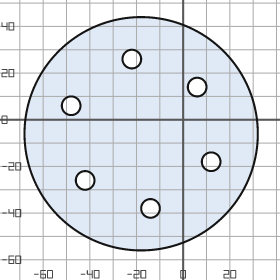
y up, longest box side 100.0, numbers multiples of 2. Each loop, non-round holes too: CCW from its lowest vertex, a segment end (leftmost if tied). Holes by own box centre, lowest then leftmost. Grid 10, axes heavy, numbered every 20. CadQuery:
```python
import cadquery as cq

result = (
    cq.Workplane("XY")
    .moveTo(-18.0, -6.0)
    .circle(50.0)
    .moveTo(-14.0, -38.0)
    .circle(4.0)
    .moveTo(-42.0, -26.0)
    .circle(4.0)
    .moveTo(12.0, -18.0)
    .circle(4.0)
    .moveTo(-48.0, 6.0)
    .circle(4.0)
    .moveTo(6.0, 14.0)
    .circle(4.0)
    .moveTo(-22.0, 26.0)
    .circle(4.0)
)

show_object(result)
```